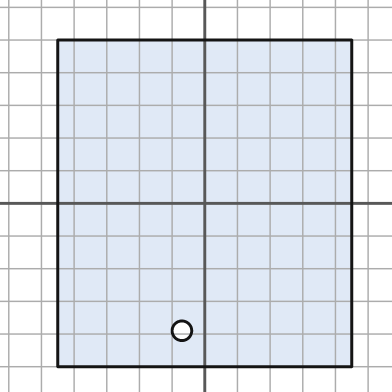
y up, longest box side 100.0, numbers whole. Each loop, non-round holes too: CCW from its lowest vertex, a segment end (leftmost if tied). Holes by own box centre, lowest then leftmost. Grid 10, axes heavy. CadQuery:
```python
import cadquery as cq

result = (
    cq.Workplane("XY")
    .moveTo(-45.0, -50.0)
    .lineTo(45.0, -50.0)
    .lineTo(45.0, 50.0)
    .lineTo(-45.0, 50.0)
    .close()
    .moveTo(-7.0, -39.0)
    .circle(3.0)
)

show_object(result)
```